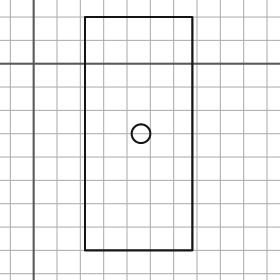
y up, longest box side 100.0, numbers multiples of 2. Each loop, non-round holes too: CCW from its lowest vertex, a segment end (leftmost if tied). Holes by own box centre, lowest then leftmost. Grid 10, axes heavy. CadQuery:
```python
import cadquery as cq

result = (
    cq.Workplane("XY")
    .moveTo(22.0, -80.0)
    .lineTo(68.0, -80.0)
    .lineTo(68.0, 20.0)
    .lineTo(22.0, 20.0)
    .close()
    .moveTo(46.0, -30.0)
    .circle(4.0)
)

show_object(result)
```